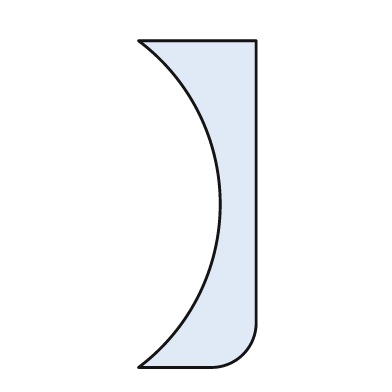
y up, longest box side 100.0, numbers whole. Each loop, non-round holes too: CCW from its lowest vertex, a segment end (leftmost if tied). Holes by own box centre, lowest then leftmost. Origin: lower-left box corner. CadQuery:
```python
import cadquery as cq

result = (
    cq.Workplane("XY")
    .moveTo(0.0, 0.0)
    .lineTo(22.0, 0.0)
    .threePointArc((32.0, 4.0), (36.0, 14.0))
    .lineTo(36.0, 100.0)
    .lineTo(0.0, 100.0)
    .threePointArc((25.0, 50.0), (0.0, 0.0))
    .close()
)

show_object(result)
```